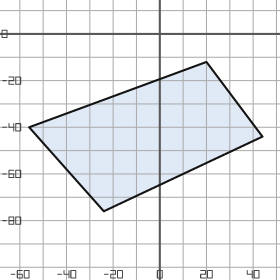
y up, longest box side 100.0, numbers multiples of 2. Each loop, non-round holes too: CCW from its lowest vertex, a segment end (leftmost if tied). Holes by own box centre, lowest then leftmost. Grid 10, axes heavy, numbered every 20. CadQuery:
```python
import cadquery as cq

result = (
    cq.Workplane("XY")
    .moveTo(-24.0, -76.0)
    .lineTo(44.0, -44.0)
    .lineTo(20.0, -12.0)
    .lineTo(-56.0, -40.0)
    .close()
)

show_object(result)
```